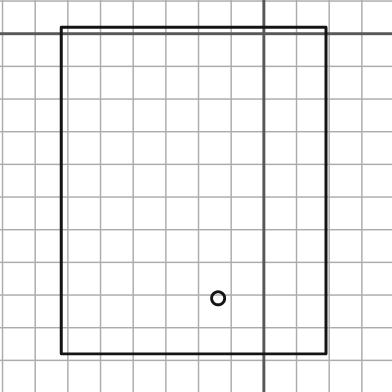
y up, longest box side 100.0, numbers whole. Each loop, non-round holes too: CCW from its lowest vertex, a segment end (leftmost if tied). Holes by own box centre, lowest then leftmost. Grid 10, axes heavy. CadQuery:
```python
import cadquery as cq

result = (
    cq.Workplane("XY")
    .moveTo(-62.0, -98.0)
    .lineTo(19.0, -98.0)
    .lineTo(19.0, 2.0)
    .lineTo(-62.0, 2.0)
    .close()
    .moveTo(-14.0, -81.0)
    .circle(2.0)
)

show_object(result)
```